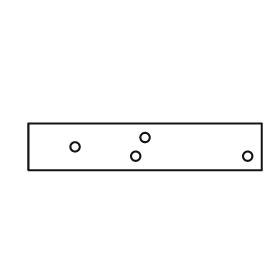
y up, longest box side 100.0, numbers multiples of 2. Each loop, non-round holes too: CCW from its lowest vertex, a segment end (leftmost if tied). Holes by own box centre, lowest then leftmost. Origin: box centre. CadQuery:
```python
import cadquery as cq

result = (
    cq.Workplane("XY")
    .moveTo(-50.0, -10.0)
    .lineTo(50.0, -10.0)
    .lineTo(50.0, 10.0)
    .lineTo(-50.0, 10.0)
    .close()
    .moveTo(-4.0, -4.0)
    .circle(2.0)
    .moveTo(44.0, -4.0)
    .circle(2.0)
    .moveTo(-30.0, 0.0)
    .circle(2.0)
    .moveTo(0.0, 4.0)
    .circle(2.0)
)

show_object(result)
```